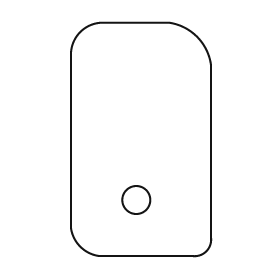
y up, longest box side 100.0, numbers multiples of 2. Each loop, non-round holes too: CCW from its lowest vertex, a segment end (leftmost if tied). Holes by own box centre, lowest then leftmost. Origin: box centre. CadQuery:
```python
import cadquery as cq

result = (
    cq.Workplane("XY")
    .moveTo(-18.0, -50.0)
    .lineTo(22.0, -50.0)
    .threePointArc((28.0, -48.0), (30.0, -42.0))
    .lineTo(30.0, 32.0)
    .threePointArc((24.0, 44.0), (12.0, 50.0))
    .lineTo(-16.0, 50.0)
    .threePointArc((-26.0, 46.0), (-30.0, 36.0))
    .lineTo(-30.0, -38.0)
    .threePointArc((-26.0, -46.0), (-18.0, -50.0))
    .close()
    .moveTo(-2.0, -26.0)
    .circle(6.0)
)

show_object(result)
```